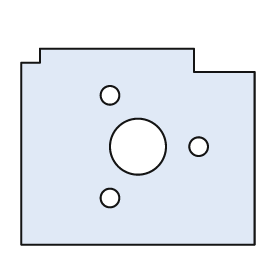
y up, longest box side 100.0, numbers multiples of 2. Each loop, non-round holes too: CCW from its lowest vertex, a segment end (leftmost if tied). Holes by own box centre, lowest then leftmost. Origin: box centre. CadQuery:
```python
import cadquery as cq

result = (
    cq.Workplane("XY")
    .moveTo(-50.0, -42.0)
    .lineTo(50.0, -42.0)
    .lineTo(50.0, 32.0)
    .lineTo(24.0, 32.0)
    .lineTo(24.0, 42.0)
    .lineTo(-42.0, 42.0)
    .lineTo(-42.0, 36.0)
    .lineTo(-50.0, 36.0)
    .close()
    .moveTo(-12.0, -22.0)
    .circle(4.0)
    .moveTo(0.0, 0.0)
    .circle(12.0)
    .moveTo(26.0, 0.0)
    .circle(4.0)
    .moveTo(-12.0, 22.0)
    .circle(4.0)
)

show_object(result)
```